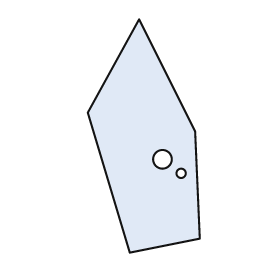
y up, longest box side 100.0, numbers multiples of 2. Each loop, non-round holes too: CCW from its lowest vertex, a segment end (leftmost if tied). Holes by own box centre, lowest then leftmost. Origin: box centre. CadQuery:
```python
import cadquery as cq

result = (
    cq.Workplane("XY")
    .moveTo(-6.0, -50.0)
    .lineTo(24.0, -44.0)
    .lineTo(22.0, 2.0)
    .lineTo(-2.0, 50.0)
    .lineTo(-24.0, 10.0)
    .close()
    .moveTo(16.0, -16.0)
    .circle(2.0)
    .moveTo(8.0, -10.0)
    .circle(4.0)
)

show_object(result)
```